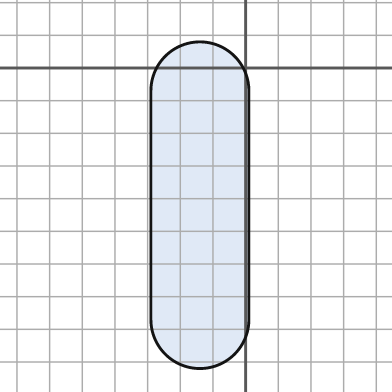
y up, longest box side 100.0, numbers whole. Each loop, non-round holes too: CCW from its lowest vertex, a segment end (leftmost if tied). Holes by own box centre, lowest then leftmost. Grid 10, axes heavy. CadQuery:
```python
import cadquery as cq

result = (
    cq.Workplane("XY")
    .moveTo(-29.0, -77.0)
    .threePointArc((-14.0, -92.0), (1.0, -77.0))
    .lineTo(1.0, -7.0)
    .threePointArc((-14.0, 8.0), (-29.0, -7.0))
    .close()
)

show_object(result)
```